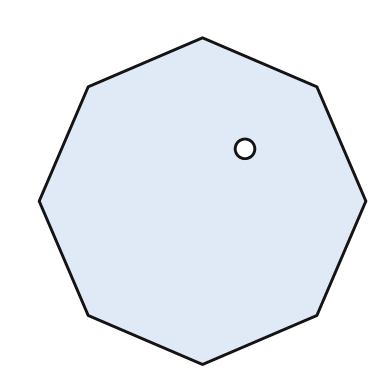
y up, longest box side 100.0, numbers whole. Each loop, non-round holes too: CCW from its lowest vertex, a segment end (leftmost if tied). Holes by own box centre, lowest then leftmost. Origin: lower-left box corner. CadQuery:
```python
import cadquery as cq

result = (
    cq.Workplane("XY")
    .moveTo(50.0, 0.0)
    .lineTo(85.0, 15.0)
    .lineTo(100.0, 50.0)
    .lineTo(85.0, 85.0)
    .lineTo(50.0, 100.0)
    .lineTo(15.0, 85.0)
    .lineTo(0.0, 50.0)
    .lineTo(15.0, 15.0)
    .close()
    .moveTo(63.0, 66.0)
    .circle(3.0)
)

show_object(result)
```